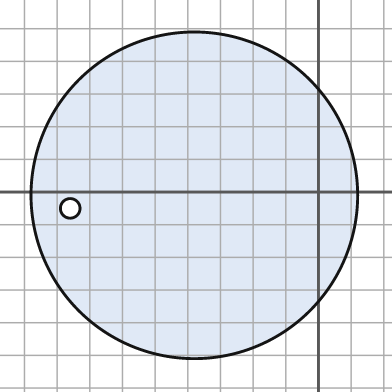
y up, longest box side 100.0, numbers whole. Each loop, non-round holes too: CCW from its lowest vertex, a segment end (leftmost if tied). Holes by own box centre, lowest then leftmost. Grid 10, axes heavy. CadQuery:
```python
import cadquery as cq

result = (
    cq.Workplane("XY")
    .moveTo(-38.0, -1.0)
    .circle(50.0)
    .moveTo(-76.0, -5.0)
    .circle(3.0)
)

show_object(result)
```